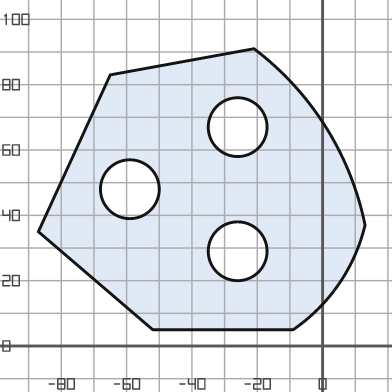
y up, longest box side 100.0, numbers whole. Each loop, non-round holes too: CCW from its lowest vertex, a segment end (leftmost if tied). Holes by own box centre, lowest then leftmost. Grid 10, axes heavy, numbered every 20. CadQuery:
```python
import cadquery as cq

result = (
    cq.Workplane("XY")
    .moveTo(-52.0, 5.0)
    .lineTo(-9.0, 5.0)
    .threePointArc((5.0, 19.0), (13.0, 37.0))
    .threePointArc((1.0, 67.0), (-21.0, 91.0))
    .lineTo(-65.0, 83.0)
    .lineTo(-87.0, 35.0)
    .close()
    .moveTo(-26.0, 29.0)
    .circle(9.0)
    .moveTo(-59.0, 48.0)
    .circle(9.0)
    .moveTo(-26.0, 67.0)
    .circle(9.0)
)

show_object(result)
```